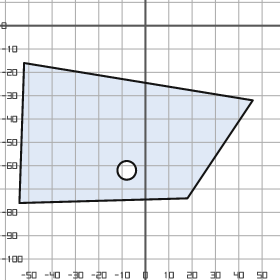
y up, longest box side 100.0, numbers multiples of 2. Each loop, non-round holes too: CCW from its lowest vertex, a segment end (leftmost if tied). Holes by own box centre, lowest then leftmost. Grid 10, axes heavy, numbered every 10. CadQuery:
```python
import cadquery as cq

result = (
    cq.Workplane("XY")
    .moveTo(-54.0, -76.0)
    .lineTo(18.0, -74.0)
    .lineTo(46.0, -32.0)
    .lineTo(-52.0, -16.0)
    .close()
    .moveTo(-8.0, -62.0)
    .circle(4.0)
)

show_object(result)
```